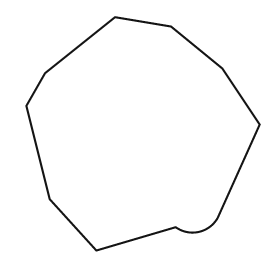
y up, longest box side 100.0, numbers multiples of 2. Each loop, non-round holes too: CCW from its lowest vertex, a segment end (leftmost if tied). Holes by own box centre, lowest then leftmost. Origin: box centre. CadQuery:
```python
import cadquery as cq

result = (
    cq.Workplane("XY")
    .moveTo(-20.0, -50.0)
    .lineTo(14.0, -40.0)
    .threePointArc((24.0, -42.0), (32.0, -36.0))
    .lineTo(50.0, 4.0)
    .lineTo(34.0, 28.0)
    .lineTo(12.0, 46.0)
    .lineTo(-12.0, 50.0)
    .lineTo(-42.0, 26.0)
    .lineTo(-50.0, 12.0)
    .lineTo(-40.0, -28.0)
    .close()
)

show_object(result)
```